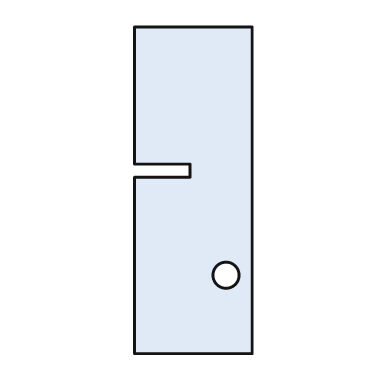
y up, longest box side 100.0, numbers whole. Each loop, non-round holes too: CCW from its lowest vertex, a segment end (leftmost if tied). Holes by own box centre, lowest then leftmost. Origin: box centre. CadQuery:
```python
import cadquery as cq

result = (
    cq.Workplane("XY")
    .moveTo(-18.0, -50.0)
    .lineTo(18.0, -50.0)
    .lineTo(18.0, 50.0)
    .lineTo(-18.0, 50.0)
    .lineTo(-18.0, 8.0)
    .lineTo(-1.0, 8.0)
    .lineTo(-1.0, 4.0)
    .lineTo(-18.0, 4.0)
    .close()
    .moveTo(10.0, -26.0)
    .circle(4.0)
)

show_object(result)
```